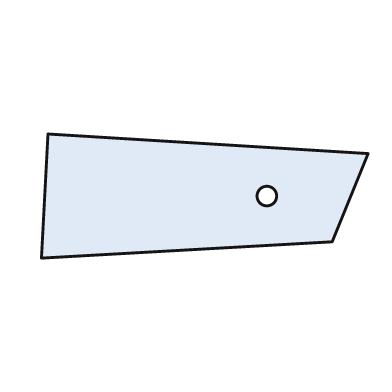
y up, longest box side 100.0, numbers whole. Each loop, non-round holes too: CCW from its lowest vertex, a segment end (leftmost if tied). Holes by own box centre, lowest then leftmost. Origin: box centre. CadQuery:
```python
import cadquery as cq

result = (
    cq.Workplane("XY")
    .moveTo(-50.0, -19.0)
    .lineTo(39.0, -14.0)
    .lineTo(50.0, 13.0)
    .lineTo(-48.0, 19.0)
    .close()
    .moveTo(19.0, 0.0)
    .circle(3.0)
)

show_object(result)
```